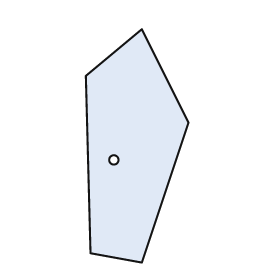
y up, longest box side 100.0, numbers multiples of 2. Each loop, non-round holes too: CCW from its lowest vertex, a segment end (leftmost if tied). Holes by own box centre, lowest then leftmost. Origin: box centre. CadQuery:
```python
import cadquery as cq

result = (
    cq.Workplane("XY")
    .moveTo(2.0, -50.0)
    .lineTo(22.0, 10.0)
    .lineTo(2.0, 50.0)
    .lineTo(-22.0, 30.0)
    .lineTo(-20.0, -46.0)
    .close()
    .moveTo(-10.0, -6.0)
    .circle(2.0)
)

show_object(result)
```